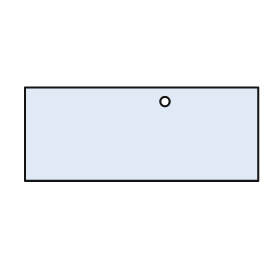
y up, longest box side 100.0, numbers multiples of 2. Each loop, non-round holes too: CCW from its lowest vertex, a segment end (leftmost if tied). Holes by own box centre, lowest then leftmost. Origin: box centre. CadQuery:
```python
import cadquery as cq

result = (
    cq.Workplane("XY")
    .moveTo(-50.0, -20.0)
    .lineTo(50.0, -20.0)
    .lineTo(50.0, 20.0)
    .lineTo(-50.0, 20.0)
    .close()
    .moveTo(10.0, 14.0)
    .circle(2.0)
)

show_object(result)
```